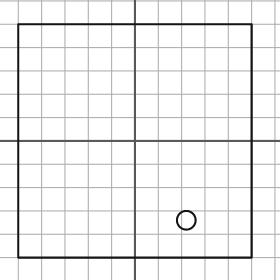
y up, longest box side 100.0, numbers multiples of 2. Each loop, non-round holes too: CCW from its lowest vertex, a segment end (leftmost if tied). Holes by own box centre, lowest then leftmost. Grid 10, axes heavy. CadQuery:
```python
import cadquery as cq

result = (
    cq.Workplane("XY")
    .moveTo(-50.0, -50.0)
    .lineTo(50.0, -50.0)
    .lineTo(50.0, 50.0)
    .lineTo(-50.0, 50.0)
    .close()
    .moveTo(22.0, -34.0)
    .circle(4.0)
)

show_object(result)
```